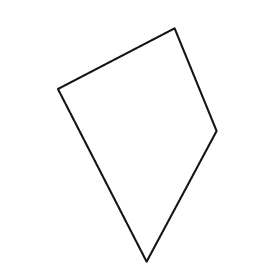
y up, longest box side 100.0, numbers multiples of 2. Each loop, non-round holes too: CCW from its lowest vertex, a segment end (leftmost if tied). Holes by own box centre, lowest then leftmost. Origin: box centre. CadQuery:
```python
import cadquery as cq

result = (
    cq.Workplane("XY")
    .moveTo(4.0, -50.0)
    .lineTo(34.0, 6.0)
    .lineTo(16.0, 50.0)
    .lineTo(-34.0, 24.0)
    .close()
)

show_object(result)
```